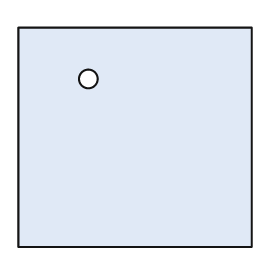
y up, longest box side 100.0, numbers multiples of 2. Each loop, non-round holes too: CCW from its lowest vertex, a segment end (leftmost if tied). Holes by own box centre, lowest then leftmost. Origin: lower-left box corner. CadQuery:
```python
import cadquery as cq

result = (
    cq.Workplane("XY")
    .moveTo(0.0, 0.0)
    .lineTo(100.0, 0.0)
    .lineTo(100.0, 94.0)
    .lineTo(0.0, 94.0)
    .close()
    .moveTo(30.0, 72.0)
    .circle(4.0)
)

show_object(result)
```